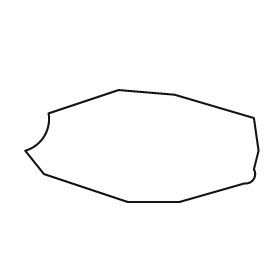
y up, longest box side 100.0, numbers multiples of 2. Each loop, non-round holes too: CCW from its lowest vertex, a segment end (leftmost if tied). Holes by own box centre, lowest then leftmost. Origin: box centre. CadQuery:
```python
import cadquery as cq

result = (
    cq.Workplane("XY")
    .moveTo(-6.0, -24.0)
    .lineTo(16.0, -24.0)
    .lineTo(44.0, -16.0)
    .threePointArc((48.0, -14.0), (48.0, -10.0))
    .lineTo(50.0, -2.0)
    .lineTo(48.0, 12.0)
    .lineTo(14.0, 22.0)
    .lineTo(-10.0, 24.0)
    .lineTo(-40.0, 14.0)
    .threePointArc((-42.0, 4.0), (-50.0, -2.0))
    .lineTo(-42.0, -12.0)
    .close()
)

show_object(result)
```